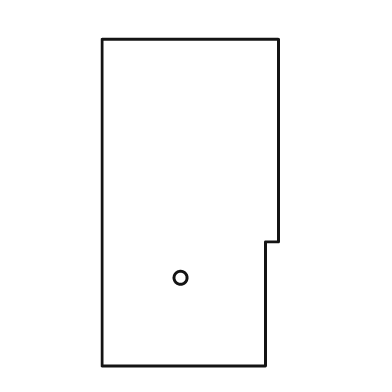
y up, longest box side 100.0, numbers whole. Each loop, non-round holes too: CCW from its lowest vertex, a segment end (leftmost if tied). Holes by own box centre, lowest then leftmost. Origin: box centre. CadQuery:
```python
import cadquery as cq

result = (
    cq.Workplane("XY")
    .moveTo(-27.0, -50.0)
    .lineTo(23.0, -50.0)
    .lineTo(23.0, -12.0)
    .lineTo(27.0, -12.0)
    .lineTo(27.0, 50.0)
    .lineTo(-27.0, 50.0)
    .close()
    .moveTo(-3.0, -23.0)
    .circle(2.0)
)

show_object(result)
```